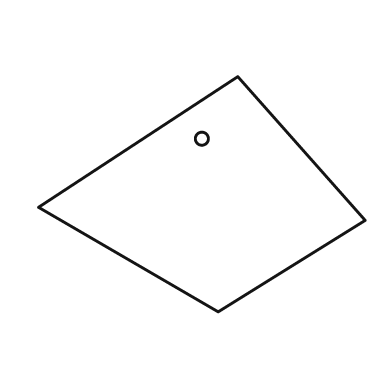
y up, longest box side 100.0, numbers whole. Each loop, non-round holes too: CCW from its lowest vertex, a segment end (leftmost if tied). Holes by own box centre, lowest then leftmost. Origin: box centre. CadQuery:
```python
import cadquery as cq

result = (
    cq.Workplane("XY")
    .moveTo(5.0, -36.0)
    .lineTo(50.0, -8.0)
    .lineTo(11.0, 36.0)
    .lineTo(-50.0, -4.0)
    .close()
    .moveTo(0.0, 17.0)
    .circle(2.0)
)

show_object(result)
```